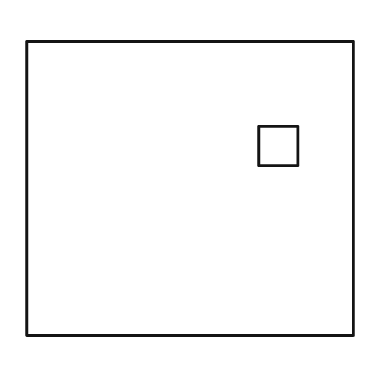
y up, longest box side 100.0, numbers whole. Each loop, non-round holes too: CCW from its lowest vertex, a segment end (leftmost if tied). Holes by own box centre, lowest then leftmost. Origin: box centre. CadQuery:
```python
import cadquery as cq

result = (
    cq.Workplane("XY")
    .moveTo(-50.0, -45.0)
    .lineTo(50.0, -45.0)
    .lineTo(50.0, 45.0)
    .lineTo(-50.0, 45.0)
    .close()
    .moveTo(21.0, 7.0)
    .lineTo(33.0, 7.0)
    .lineTo(33.0, 19.0)
    .lineTo(21.0, 19.0)
    .close()
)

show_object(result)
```